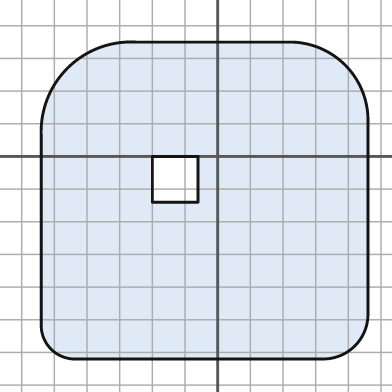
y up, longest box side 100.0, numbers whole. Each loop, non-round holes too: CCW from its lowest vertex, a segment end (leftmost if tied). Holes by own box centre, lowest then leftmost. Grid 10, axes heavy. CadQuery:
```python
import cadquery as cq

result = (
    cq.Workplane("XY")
    .moveTo(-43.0, -62.0)
    .lineTo(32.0, -62.0)
    .threePointArc((42.0, -58.0), (46.0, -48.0))
    .lineTo(46.0, 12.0)
    .threePointArc((39.0, 28.0), (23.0, 35.0))
    .lineTo(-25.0, 35.0)
    .threePointArc((-46.0, 27.0), (-54.0, 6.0))
    .lineTo(-54.0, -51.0)
    .threePointArc((-51.0, -59.0), (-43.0, -62.0))
    .close()
    .moveTo(-20.0, -14.0)
    .lineTo(-6.0, -14.0)
    .lineTo(-6.0, 0.0)
    .lineTo(-20.0, 0.0)
    .close()
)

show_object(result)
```